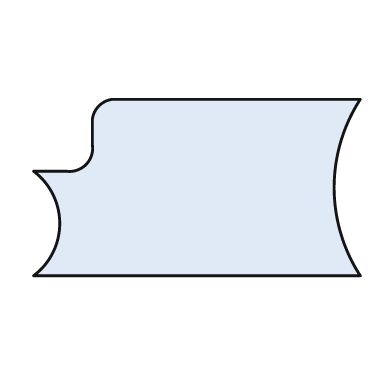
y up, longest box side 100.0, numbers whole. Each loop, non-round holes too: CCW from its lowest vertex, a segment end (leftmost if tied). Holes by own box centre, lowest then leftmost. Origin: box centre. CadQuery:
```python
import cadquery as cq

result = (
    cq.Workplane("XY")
    .moveTo(-50.0, -27.0)
    .lineTo(50.0, -27.0)
    .threePointArc((42.0, 0.0), (50.0, 27.0))
    .lineTo(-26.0, 27.0)
    .threePointArc((-30.0, 25.0), (-32.0, 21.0))
    .lineTo(-32.0, 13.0)
    .threePointArc((-34.0, 7.0), (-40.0, 5.0))
    .lineTo(-50.0, 5.0)
    .threePointArc((-42.0, -11.0), (-50.0, -27.0))
    .close()
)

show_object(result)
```